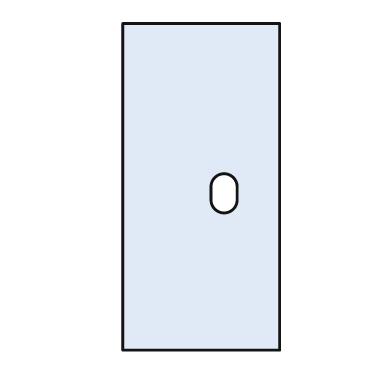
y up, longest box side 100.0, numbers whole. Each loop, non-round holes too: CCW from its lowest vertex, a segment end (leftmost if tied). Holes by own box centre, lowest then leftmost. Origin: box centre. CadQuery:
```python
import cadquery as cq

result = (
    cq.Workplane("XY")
    .moveTo(-24.0, -50.0)
    .lineTo(24.0, -50.0)
    .lineTo(24.0, 50.0)
    .lineTo(-24.0, 50.0)
    .close()
    .moveTo(3.0, -4.0)
    .threePointArc((7.0, -8.0), (11.0, -4.0))
    .lineTo(11.0, 0.0)
    .threePointArc((7.0, 4.0), (3.0, 0.0))
    .close()
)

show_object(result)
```